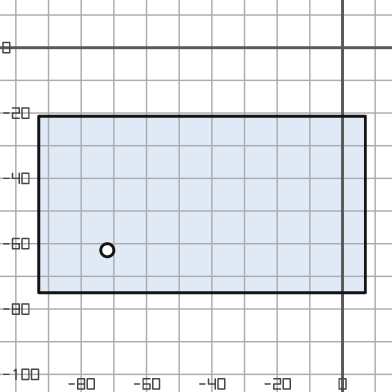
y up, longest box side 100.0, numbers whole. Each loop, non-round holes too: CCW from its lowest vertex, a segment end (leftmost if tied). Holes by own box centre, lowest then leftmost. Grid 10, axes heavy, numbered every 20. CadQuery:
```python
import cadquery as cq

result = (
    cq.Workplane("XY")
    .moveTo(-93.0, -75.0)
    .lineTo(7.0, -75.0)
    .lineTo(7.0, -21.0)
    .lineTo(-93.0, -21.0)
    .close()
    .moveTo(-72.0, -62.0)
    .circle(2.0)
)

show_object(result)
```